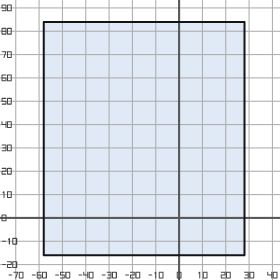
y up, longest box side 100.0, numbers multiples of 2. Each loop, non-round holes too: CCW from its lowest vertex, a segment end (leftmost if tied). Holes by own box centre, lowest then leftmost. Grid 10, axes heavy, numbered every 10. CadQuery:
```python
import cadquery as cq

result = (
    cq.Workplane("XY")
    .moveTo(-58.0, -16.0)
    .lineTo(28.0, -16.0)
    .lineTo(28.0, 84.0)
    .lineTo(-58.0, 84.0)
    .close()
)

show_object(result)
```